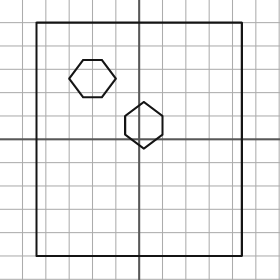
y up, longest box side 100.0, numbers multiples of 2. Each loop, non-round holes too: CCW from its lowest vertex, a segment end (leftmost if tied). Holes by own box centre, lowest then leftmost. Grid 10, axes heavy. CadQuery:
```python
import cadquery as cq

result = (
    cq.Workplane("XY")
    .moveTo(-44.0, -50.0)
    .lineTo(44.0, -50.0)
    .lineTo(44.0, 50.0)
    .lineTo(-44.0, 50.0)
    .close()
    .moveTo(2.0, -4.0)
    .lineTo(10.0, 2.0)
    .lineTo(10.0, 10.0)
    .lineTo(2.0, 16.0)
    .lineTo(-6.0, 10.0)
    .lineTo(-6.0, 2.0)
    .close()
    .moveTo(-24.0, 18.0)
    .lineTo(-16.0, 18.0)
    .lineTo(-10.0, 26.0)
    .lineTo(-16.0, 34.0)
    .lineTo(-24.0, 34.0)
    .lineTo(-30.0, 26.0)
    .close()
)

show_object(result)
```